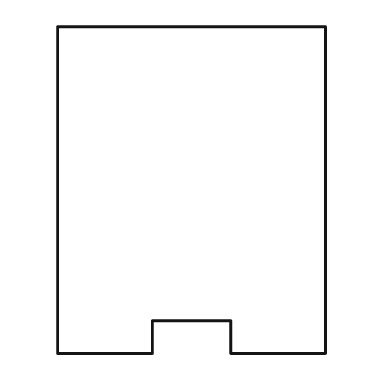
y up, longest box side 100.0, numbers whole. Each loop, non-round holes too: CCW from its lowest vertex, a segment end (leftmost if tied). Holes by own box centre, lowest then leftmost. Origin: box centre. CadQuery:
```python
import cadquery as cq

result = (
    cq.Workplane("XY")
    .moveTo(-41.0, -50.0)
    .lineTo(-12.0, -50.0)
    .lineTo(-12.0, -40.0)
    .lineTo(12.0, -40.0)
    .lineTo(12.0, -50.0)
    .lineTo(41.0, -50.0)
    .lineTo(41.0, 50.0)
    .lineTo(-41.0, 50.0)
    .close()
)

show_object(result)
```